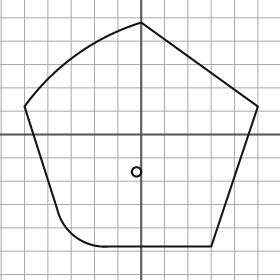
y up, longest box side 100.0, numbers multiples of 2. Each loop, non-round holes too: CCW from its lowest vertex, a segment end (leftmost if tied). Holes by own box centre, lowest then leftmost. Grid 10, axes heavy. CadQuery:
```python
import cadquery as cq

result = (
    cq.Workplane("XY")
    .moveTo(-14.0, -48.0)
    .lineTo(30.0, -48.0)
    .lineTo(50.0, 12.0)
    .lineTo(0.0, 48.0)
    .threePointArc((-28.0, 34.0), (-50.0, 12.0))
    .lineTo(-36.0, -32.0)
    .threePointArc((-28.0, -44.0), (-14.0, -48.0))
    .close()
    .moveTo(-2.0, -16.0)
    .circle(2.0)
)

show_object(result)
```